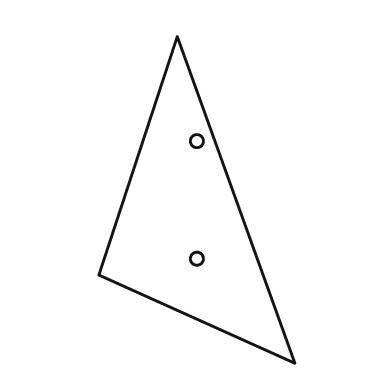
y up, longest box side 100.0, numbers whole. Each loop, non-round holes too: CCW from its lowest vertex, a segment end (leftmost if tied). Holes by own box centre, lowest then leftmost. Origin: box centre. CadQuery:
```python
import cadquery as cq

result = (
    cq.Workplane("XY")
    .moveTo(30.0, -50.0)
    .lineTo(-6.0, 50.0)
    .lineTo(-30.0, -23.0)
    .close()
    .moveTo(0.0, -18.0)
    .circle(2.0)
    .moveTo(0.0, 18.0)
    .circle(2.0)
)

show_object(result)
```